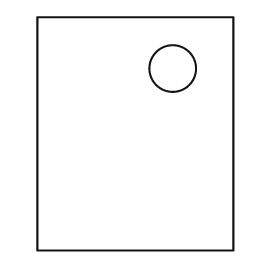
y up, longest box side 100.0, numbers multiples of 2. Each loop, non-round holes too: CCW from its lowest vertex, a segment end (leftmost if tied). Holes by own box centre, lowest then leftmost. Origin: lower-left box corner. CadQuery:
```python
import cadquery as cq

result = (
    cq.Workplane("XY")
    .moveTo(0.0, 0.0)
    .lineTo(84.0, 0.0)
    .lineTo(84.0, 100.0)
    .lineTo(0.0, 100.0)
    .close()
    .moveTo(58.0, 78.0)
    .circle(10.0)
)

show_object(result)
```